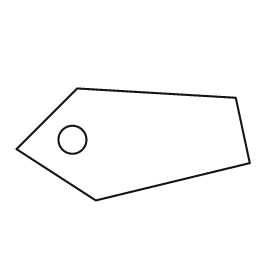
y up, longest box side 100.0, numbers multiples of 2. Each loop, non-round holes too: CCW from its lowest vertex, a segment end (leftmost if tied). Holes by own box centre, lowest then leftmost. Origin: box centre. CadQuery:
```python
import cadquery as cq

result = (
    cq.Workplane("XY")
    .moveTo(-16.0, -24.0)
    .lineTo(50.0, -8.0)
    .lineTo(44.0, 20.0)
    .lineTo(-24.0, 24.0)
    .lineTo(-50.0, -2.0)
    .close()
    .moveTo(-26.0, 2.0)
    .circle(6.0)
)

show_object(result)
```